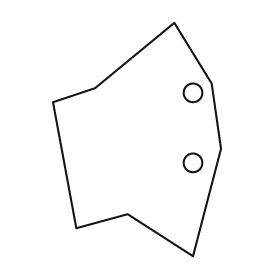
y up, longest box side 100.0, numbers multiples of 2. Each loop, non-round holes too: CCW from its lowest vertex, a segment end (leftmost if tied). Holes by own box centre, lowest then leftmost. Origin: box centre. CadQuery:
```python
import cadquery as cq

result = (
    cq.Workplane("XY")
    .moveTo(24.0, -50.0)
    .lineTo(36.0, -4.0)
    .lineTo(32.0, 24.0)
    .lineTo(16.0, 50.0)
    .lineTo(-18.0, 22.0)
    .lineTo(-36.0, 16.0)
    .lineTo(-26.0, -38.0)
    .lineTo(-4.0, -32.0)
    .close()
    .moveTo(24.0, -10.0)
    .circle(4.0)
    .moveTo(24.0, 20.0)
    .circle(4.0)
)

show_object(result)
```